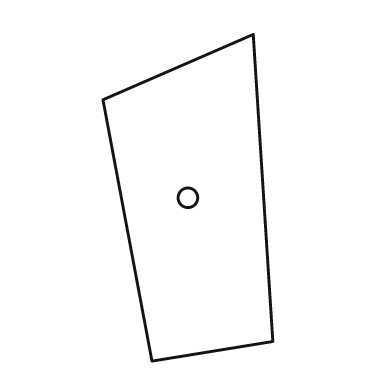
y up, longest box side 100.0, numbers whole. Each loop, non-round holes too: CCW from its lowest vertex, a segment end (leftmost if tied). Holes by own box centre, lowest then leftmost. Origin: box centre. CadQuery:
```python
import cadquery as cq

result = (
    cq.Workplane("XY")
    .moveTo(-11.0, -50.0)
    .lineTo(26.0, -44.0)
    .lineTo(20.0, 50.0)
    .lineTo(-26.0, 30.0)
    .close()
    .moveTo(0.0, 0.0)
    .circle(3.0)
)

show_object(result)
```